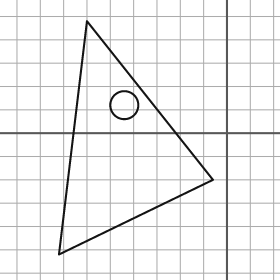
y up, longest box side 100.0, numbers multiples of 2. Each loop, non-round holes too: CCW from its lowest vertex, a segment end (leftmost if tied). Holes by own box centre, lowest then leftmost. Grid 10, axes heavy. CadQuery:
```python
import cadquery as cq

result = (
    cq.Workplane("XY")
    .moveTo(-72.0, -52.0)
    .lineTo(-6.0, -20.0)
    .lineTo(-60.0, 48.0)
    .close()
    .moveTo(-44.0, 12.0)
    .circle(6.0)
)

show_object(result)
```